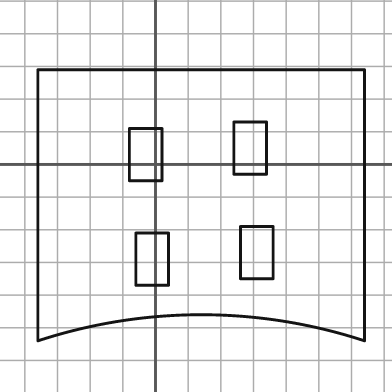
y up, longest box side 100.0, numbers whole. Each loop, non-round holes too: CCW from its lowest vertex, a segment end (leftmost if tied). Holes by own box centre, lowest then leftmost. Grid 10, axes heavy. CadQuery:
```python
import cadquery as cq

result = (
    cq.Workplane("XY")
    .moveTo(-36.0, -54.0)
    .threePointArc((14.0, -46.0), (64.0, -54.0))
    .lineTo(64.0, 29.0)
    .lineTo(-36.0, 29.0)
    .close()
    .moveTo(-6.0, -37.0)
    .lineTo(4.0, -37.0)
    .lineTo(4.0, -21.0)
    .lineTo(-6.0, -21.0)
    .close()
    .moveTo(26.0, -35.0)
    .lineTo(36.0, -35.0)
    .lineTo(36.0, -19.0)
    .lineTo(26.0, -19.0)
    .close()
    .moveTo(-8.0, -5.0)
    .lineTo(2.0, -5.0)
    .lineTo(2.0, 11.0)
    .lineTo(-8.0, 11.0)
    .close()
    .moveTo(24.0, -3.0)
    .lineTo(34.0, -3.0)
    .lineTo(34.0, 13.0)
    .lineTo(24.0, 13.0)
    .close()
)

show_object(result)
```